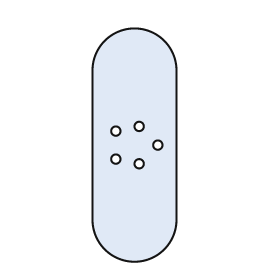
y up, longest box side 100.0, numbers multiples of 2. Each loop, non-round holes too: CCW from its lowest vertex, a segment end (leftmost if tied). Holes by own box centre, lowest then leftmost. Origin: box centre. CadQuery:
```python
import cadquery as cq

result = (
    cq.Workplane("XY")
    .moveTo(-18.0, -32.0)
    .threePointArc((0.0, -50.0), (18.0, -32.0))
    .lineTo(18.0, 32.0)
    .threePointArc((0.0, 50.0), (-18.0, 32.0))
    .close()
    .moveTo(2.0, -8.0)
    .circle(2.0)
    .moveTo(-8.0, -6.0)
    .circle(2.0)
    .moveTo(10.0, 0.0)
    .circle(2.0)
    .moveTo(-8.0, 6.0)
    .circle(2.0)
    .moveTo(2.0, 8.0)
    .circle(2.0)
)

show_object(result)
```